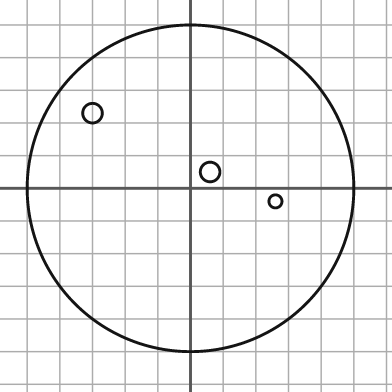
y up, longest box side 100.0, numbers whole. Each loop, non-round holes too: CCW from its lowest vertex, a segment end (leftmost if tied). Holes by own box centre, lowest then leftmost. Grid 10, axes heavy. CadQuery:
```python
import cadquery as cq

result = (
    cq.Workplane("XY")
    .moveTo(0.0, 0.0)
    .circle(50.0)
    .moveTo(26.0, -4.0)
    .circle(2.0)
    .moveTo(6.0, 5.0)
    .circle(3.0)
    .moveTo(-30.0, 23.0)
    .circle(3.0)
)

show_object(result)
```